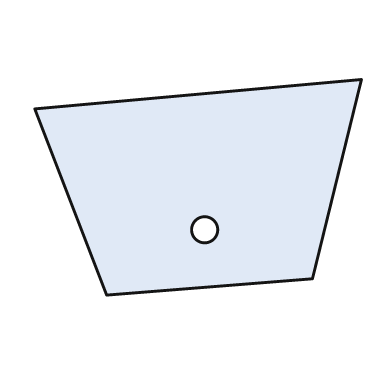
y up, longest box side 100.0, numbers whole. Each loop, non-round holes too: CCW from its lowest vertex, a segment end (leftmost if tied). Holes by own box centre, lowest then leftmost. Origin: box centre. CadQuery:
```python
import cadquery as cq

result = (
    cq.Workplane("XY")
    .moveTo(-28.0, -33.0)
    .lineTo(35.0, -28.0)
    .lineTo(50.0, 33.0)
    .lineTo(-50.0, 24.0)
    .close()
    .moveTo(2.0, -13.0)
    .circle(4.0)
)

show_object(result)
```